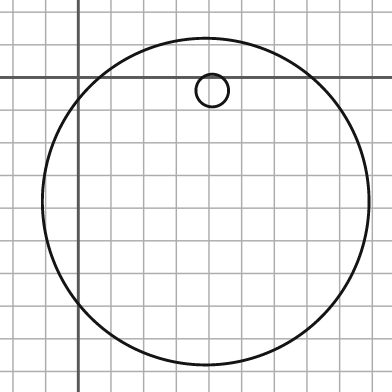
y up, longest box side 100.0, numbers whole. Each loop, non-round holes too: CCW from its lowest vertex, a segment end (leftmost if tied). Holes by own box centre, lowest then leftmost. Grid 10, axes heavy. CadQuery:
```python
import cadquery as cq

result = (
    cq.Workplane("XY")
    .moveTo(39.0, -38.0)
    .circle(50.0)
    .moveTo(41.0, -4.0)
    .circle(5.0)
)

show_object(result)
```